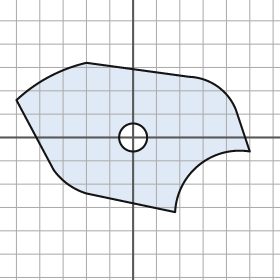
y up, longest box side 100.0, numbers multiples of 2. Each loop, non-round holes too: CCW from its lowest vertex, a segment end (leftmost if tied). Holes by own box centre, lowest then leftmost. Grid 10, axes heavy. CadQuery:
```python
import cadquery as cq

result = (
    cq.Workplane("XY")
    .moveTo(18.0, -32.0)
    .threePointArc((28.0, -12.0), (50.0, -6.0))
    .lineTo(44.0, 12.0)
    .threePointArc((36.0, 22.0), (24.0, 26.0))
    .lineTo(-20.0, 32.0)
    .threePointArc((-36.0, 26.0), (-50.0, 16.0))
    .lineTo(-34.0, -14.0)
    .threePointArc((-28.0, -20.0), (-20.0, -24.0))
    .close()
    .moveTo(0.0, 0.0)
    .circle(6.0)
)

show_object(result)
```